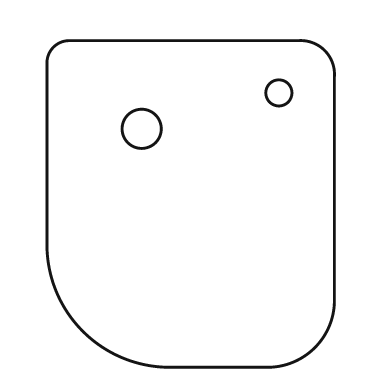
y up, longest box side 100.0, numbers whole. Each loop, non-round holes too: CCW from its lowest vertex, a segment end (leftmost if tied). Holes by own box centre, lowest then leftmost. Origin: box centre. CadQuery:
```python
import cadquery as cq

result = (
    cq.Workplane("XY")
    .moveTo(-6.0, -50.0)
    .lineTo(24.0, -50.0)
    .threePointArc((38.0, -44.0), (44.0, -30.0))
    .lineTo(44.0, 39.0)
    .threePointArc((41.0, 47.0), (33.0, 50.0))
    .lineTo(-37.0, 50.0)
    .threePointArc((-42.0, 48.0), (-44.0, 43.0))
    .lineTo(-44.0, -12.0)
    .threePointArc((-33.0, -39.0), (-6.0, -50.0))
    .close()
    .moveTo(-15.0, 23.0)
    .circle(6.0)
    .moveTo(27.0, 34.0)
    .circle(4.0)
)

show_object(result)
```